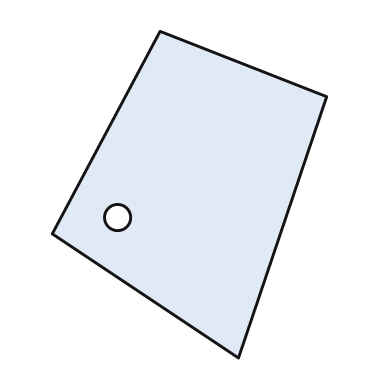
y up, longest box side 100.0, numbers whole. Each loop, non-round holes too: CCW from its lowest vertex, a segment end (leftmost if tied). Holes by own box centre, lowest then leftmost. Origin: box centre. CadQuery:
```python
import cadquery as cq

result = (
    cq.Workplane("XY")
    .moveTo(15.0, -50.0)
    .lineTo(42.0, 30.0)
    .lineTo(-9.0, 50.0)
    .lineTo(-42.0, -12.0)
    .close()
    .moveTo(-22.0, -7.0)
    .circle(4.0)
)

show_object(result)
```